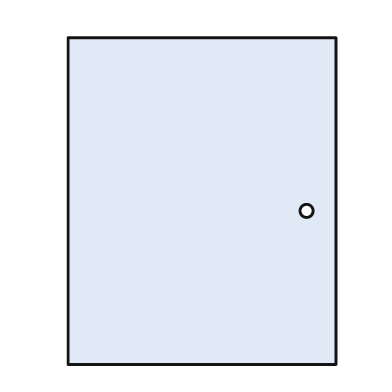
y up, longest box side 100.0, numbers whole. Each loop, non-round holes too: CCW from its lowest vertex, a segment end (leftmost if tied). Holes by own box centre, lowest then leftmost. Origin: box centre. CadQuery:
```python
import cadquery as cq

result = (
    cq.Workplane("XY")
    .moveTo(-41.0, -50.0)
    .lineTo(41.0, -50.0)
    .lineTo(41.0, 50.0)
    .lineTo(-41.0, 50.0)
    .close()
    .moveTo(32.0, -3.0)
    .circle(2.0)
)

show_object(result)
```